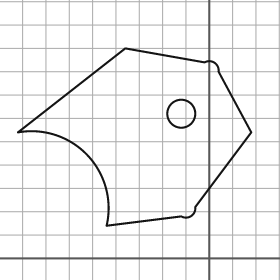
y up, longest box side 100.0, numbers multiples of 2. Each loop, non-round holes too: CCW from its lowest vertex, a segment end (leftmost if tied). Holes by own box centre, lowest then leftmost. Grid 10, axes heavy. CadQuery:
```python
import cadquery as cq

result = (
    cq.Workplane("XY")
    .moveTo(-44.0, 14.0)
    .lineTo(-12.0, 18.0)
    .threePointArc((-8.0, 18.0), (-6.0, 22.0))
    .lineTo(18.0, 54.0)
    .lineTo(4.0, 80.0)
    .threePointArc((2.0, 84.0), (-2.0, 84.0))
    .lineTo(-36.0, 90.0)
    .lineTo(-82.0, 54.0)
    .threePointArc((-52.0, 44.0), (-44.0, 14.0))
    .close()
    .moveTo(-12.0, 62.0)
    .circle(6.0)
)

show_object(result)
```